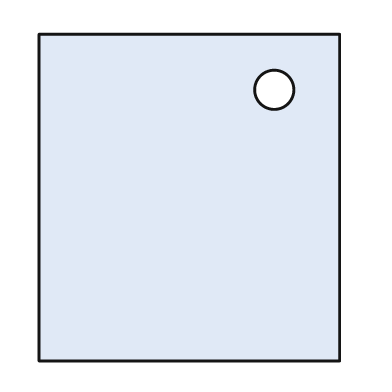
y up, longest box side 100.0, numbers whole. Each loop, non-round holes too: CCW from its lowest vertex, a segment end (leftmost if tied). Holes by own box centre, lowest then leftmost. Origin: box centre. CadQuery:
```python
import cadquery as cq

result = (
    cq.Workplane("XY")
    .moveTo(-46.0, -50.0)
    .lineTo(46.0, -50.0)
    .lineTo(46.0, 50.0)
    .lineTo(-46.0, 50.0)
    .close()
    .moveTo(26.0, 33.0)
    .circle(6.0)
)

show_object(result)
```